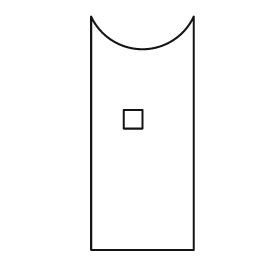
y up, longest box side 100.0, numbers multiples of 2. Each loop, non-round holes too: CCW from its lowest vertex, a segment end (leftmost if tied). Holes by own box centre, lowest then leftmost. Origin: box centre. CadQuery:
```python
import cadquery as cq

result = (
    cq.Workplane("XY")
    .moveTo(-22.0, -50.0)
    .lineTo(22.0, -50.0)
    .lineTo(22.0, 50.0)
    .threePointArc((0.0, 36.0), (-22.0, 50.0))
    .close()
    .moveTo(-8.0, 2.0)
    .lineTo(0.0, 2.0)
    .lineTo(0.0, 10.0)
    .lineTo(-8.0, 10.0)
    .close()
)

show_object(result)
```